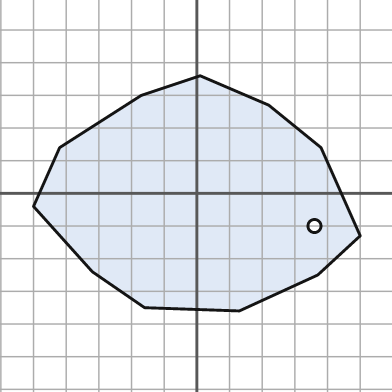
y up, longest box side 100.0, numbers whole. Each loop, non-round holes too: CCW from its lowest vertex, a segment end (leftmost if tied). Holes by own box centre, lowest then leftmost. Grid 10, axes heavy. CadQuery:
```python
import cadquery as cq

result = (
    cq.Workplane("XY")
    .moveTo(13.0, -36.0)
    .lineTo(37.0, -25.0)
    .lineTo(50.0, -13.0)
    .lineTo(38.0, 14.0)
    .lineTo(22.0, 27.0)
    .lineTo(1.0, 36.0)
    .lineTo(-17.0, 30.0)
    .lineTo(-42.0, 14.0)
    .lineTo(-50.0, -4.0)
    .lineTo(-32.0, -24.0)
    .lineTo(-16.0, -35.0)
    .close()
    .moveTo(36.0, -10.0)
    .circle(2.0)
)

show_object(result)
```